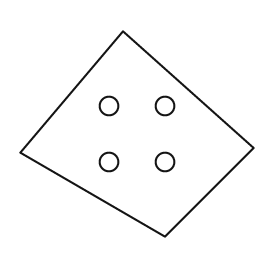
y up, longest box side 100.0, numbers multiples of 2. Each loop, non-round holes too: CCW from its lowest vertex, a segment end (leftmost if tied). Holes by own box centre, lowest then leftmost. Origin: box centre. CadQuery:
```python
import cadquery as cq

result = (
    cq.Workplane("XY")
    .moveTo(12.0, -44.0)
    .lineTo(50.0, -6.0)
    .lineTo(-6.0, 44.0)
    .lineTo(-50.0, -8.0)
    .close()
    .moveTo(-12.0, -12.0)
    .circle(4.0)
    .moveTo(12.0, -12.0)
    .circle(4.0)
    .moveTo(-12.0, 12.0)
    .circle(4.0)
    .moveTo(12.0, 12.0)
    .circle(4.0)
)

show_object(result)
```